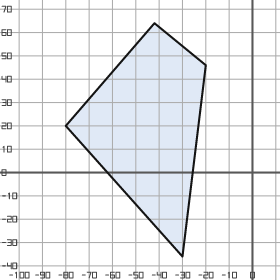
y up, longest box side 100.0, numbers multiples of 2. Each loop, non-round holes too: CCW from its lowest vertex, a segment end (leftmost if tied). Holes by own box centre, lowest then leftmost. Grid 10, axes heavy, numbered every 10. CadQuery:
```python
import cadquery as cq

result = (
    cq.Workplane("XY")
    .moveTo(-30.0, -36.0)
    .lineTo(-20.0, 46.0)
    .lineTo(-42.0, 64.0)
    .lineTo(-80.0, 20.0)
    .close()
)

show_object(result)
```